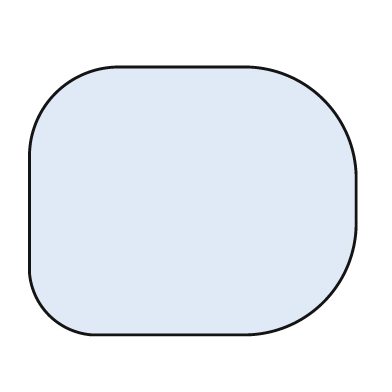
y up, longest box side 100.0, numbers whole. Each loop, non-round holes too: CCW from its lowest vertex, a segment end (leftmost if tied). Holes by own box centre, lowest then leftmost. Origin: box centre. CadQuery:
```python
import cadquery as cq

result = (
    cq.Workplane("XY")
    .moveTo(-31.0, -41.0)
    .lineTo(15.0, -41.0)
    .threePointArc((40.0, -31.0), (50.0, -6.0))
    .lineTo(50.0, 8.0)
    .threePointArc((40.0, 31.0), (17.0, 41.0))
    .lineTo(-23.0, 41.0)
    .threePointArc((-42.0, 33.0), (-50.0, 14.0))
    .lineTo(-50.0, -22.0)
    .threePointArc((-44.0, -35.0), (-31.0, -41.0))
    .close()
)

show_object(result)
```